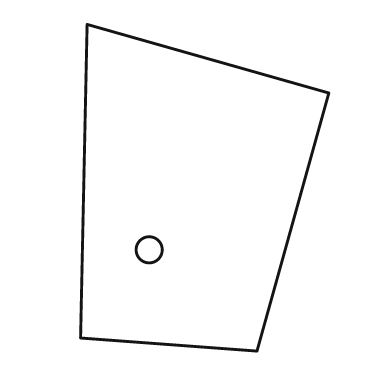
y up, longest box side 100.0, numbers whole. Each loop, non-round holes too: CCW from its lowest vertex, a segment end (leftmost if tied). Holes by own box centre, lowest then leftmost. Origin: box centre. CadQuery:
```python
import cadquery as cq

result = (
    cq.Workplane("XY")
    .moveTo(16.0, -50.0)
    .lineTo(38.0, 29.0)
    .lineTo(-36.0, 50.0)
    .lineTo(-38.0, -46.0)
    .close()
    .moveTo(-17.0, -19.0)
    .circle(4.0)
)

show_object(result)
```